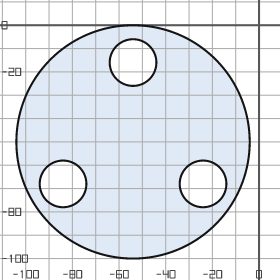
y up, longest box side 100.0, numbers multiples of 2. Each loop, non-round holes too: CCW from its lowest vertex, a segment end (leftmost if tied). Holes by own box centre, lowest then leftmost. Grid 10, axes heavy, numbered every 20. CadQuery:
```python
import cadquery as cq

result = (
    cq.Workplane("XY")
    .moveTo(-54.0, -50.0)
    .circle(50.0)
    .moveTo(-84.0, -68.0)
    .circle(10.0)
    .moveTo(-24.0, -68.0)
    .circle(10.0)
    .moveTo(-54.0, -16.0)
    .circle(10.0)
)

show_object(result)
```